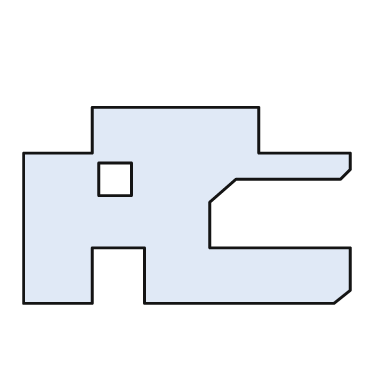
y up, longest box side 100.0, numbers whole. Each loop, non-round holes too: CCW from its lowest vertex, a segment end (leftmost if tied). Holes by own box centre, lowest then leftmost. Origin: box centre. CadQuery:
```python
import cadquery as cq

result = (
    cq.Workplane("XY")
    .moveTo(-50.0, -30.0)
    .lineTo(-29.0, -30.0)
    .lineTo(-29.0, -13.0)
    .lineTo(-13.0, -13.0)
    .lineTo(-13.0, -30.0)
    .lineTo(45.0, -30.0)
    .lineTo(50.0, -26.0)
    .lineTo(50.0, -13.0)
    .lineTo(7.0, -13.0)
    .lineTo(7.0, 1.0)
    .lineTo(15.0, 8.0)
    .lineTo(47.0, 8.0)
    .lineTo(50.0, 11.0)
    .lineTo(50.0, 16.0)
    .lineTo(22.0, 16.0)
    .lineTo(22.0, 30.0)
    .lineTo(-29.0, 30.0)
    .lineTo(-29.0, 16.0)
    .lineTo(-50.0, 16.0)
    .close()
    .moveTo(-27.0, 3.0)
    .lineTo(-17.0, 3.0)
    .lineTo(-17.0, 13.0)
    .lineTo(-27.0, 13.0)
    .close()
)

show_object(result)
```